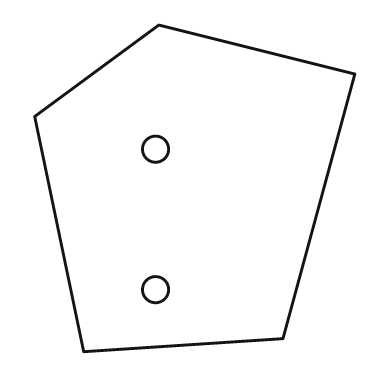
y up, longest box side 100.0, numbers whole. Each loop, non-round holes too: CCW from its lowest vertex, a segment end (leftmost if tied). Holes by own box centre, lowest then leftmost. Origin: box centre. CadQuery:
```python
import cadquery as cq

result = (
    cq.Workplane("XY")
    .moveTo(-34.0, -50.0)
    .lineTo(27.0, -46.0)
    .lineTo(49.0, 35.0)
    .lineTo(-11.0, 50.0)
    .lineTo(-49.0, 22.0)
    .close()
    .moveTo(-12.0, -31.0)
    .circle(4.0)
    .moveTo(-12.0, 12.0)
    .circle(4.0)
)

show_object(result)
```